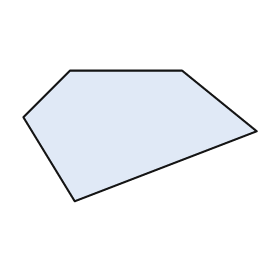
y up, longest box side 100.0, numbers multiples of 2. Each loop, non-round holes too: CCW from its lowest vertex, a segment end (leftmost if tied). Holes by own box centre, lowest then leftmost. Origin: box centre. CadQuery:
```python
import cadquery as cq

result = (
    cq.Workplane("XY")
    .moveTo(-28.0, -28.0)
    .lineTo(50.0, 2.0)
    .lineTo(18.0, 28.0)
    .lineTo(-30.0, 28.0)
    .lineTo(-50.0, 8.0)
    .close()
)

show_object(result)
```